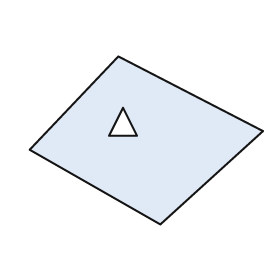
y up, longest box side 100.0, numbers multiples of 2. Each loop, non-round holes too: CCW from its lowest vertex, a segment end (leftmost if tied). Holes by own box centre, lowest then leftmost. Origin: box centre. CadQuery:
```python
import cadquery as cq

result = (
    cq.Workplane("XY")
    .moveTo(6.0, -36.0)
    .lineTo(50.0, 4.0)
    .lineTo(-12.0, 36.0)
    .lineTo(-50.0, -4.0)
    .close()
    .moveTo(-16.0, 2.0)
    .lineTo(-4.0, 2.0)
    .lineTo(-10.0, 14.0)
    .close()
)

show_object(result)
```